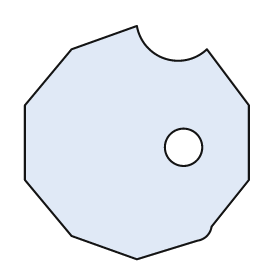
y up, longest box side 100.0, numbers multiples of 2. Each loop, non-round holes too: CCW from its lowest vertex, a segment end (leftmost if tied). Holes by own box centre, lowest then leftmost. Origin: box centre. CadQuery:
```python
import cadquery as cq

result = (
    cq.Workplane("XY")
    .moveTo(0.0, -50.0)
    .lineTo(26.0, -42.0)
    .threePointArc((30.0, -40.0), (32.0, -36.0))
    .lineTo(48.0, -16.0)
    .lineTo(48.0, 16.0)
    .lineTo(30.0, 40.0)
    .threePointArc((12.0, 36.0), (0.0, 50.0))
    .lineTo(-28.0, 40.0)
    .lineTo(-48.0, 16.0)
    .lineTo(-48.0, -16.0)
    .lineTo(-28.0, -40.0)
    .close()
    .moveTo(20.0, -2.0)
    .circle(8.0)
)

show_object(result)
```